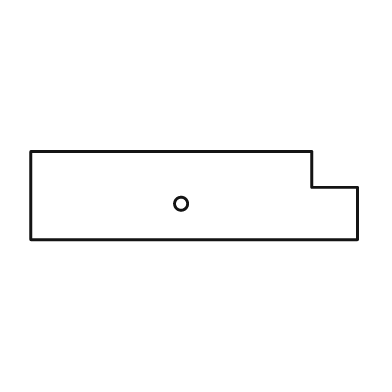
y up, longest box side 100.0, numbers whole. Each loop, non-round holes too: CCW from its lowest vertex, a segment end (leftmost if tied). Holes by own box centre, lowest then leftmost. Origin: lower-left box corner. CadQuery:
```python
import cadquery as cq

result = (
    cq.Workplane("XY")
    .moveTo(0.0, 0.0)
    .lineTo(100.0, 0.0)
    .lineTo(100.0, 16.0)
    .lineTo(86.0, 16.0)
    .lineTo(86.0, 27.0)
    .lineTo(0.0, 27.0)
    .close()
    .moveTo(46.0, 11.0)
    .circle(2.0)
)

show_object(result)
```